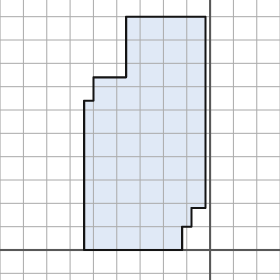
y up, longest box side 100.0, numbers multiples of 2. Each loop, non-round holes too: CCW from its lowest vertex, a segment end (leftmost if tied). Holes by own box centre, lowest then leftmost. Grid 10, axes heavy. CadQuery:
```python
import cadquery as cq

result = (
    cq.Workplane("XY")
    .moveTo(-54.0, 0.0)
    .lineTo(-12.0, 0.0)
    .lineTo(-12.0, 10.0)
    .lineTo(-8.0, 10.0)
    .lineTo(-8.0, 18.0)
    .lineTo(-2.0, 18.0)
    .lineTo(-2.0, 100.0)
    .lineTo(-36.0, 100.0)
    .lineTo(-36.0, 74.0)
    .lineTo(-50.0, 74.0)
    .lineTo(-50.0, 64.0)
    .lineTo(-54.0, 64.0)
    .close()
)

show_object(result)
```